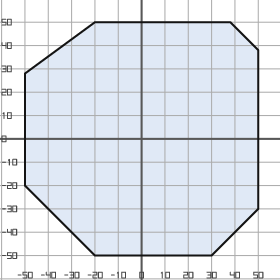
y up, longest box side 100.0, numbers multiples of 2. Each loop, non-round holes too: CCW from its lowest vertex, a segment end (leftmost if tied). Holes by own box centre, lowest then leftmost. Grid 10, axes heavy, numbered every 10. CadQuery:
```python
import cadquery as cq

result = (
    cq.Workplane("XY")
    .moveTo(-20.0, -50.0)
    .lineTo(30.0, -50.0)
    .lineTo(50.0, -30.0)
    .lineTo(50.0, 38.0)
    .lineTo(38.0, 50.0)
    .lineTo(-20.0, 50.0)
    .lineTo(-50.0, 28.0)
    .lineTo(-50.0, -20.0)
    .close()
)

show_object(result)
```